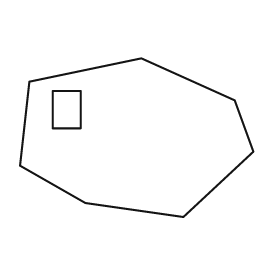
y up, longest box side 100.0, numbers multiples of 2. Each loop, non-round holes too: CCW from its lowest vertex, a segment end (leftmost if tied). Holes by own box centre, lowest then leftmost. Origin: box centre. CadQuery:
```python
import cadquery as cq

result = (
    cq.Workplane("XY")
    .moveTo(20.0, -34.0)
    .lineTo(50.0, -6.0)
    .lineTo(42.0, 16.0)
    .lineTo(2.0, 34.0)
    .lineTo(-46.0, 24.0)
    .lineTo(-50.0, -12.0)
    .lineTo(-22.0, -28.0)
    .close()
    .moveTo(-36.0, 4.0)
    .lineTo(-24.0, 4.0)
    .lineTo(-24.0, 20.0)
    .lineTo(-36.0, 20.0)
    .close()
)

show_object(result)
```